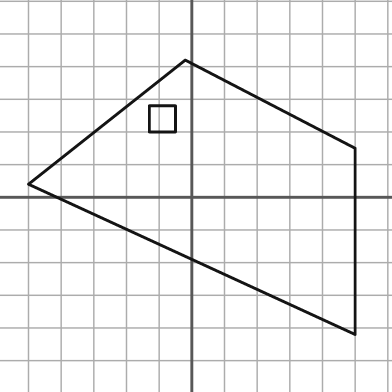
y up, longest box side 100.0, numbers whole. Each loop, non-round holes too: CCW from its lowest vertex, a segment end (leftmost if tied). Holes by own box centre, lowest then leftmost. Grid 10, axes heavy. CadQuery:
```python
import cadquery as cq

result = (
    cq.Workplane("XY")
    .moveTo(50.0, -42.0)
    .lineTo(50.0, 15.0)
    .lineTo(-2.0, 42.0)
    .lineTo(-50.0, 4.0)
    .close()
    .moveTo(-13.0, 20.0)
    .lineTo(-5.0, 20.0)
    .lineTo(-5.0, 28.0)
    .lineTo(-13.0, 28.0)
    .close()
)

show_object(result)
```